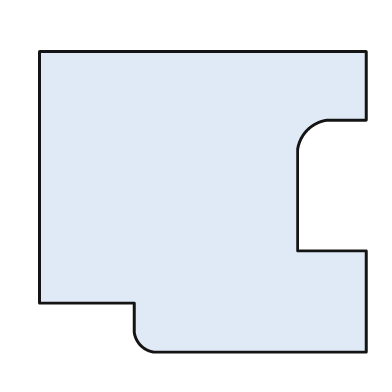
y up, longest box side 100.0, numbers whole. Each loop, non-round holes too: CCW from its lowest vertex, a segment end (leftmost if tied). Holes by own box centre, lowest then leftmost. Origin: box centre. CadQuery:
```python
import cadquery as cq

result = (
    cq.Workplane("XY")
    .moveTo(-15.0, -46.0)
    .lineTo(50.0, -46.0)
    .lineTo(50.0, -15.0)
    .lineTo(29.0, -15.0)
    .lineTo(29.0, 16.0)
    .threePointArc((32.0, 22.0), (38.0, 25.0))
    .lineTo(50.0, 25.0)
    .lineTo(50.0, 46.0)
    .lineTo(-50.0, 46.0)
    .lineTo(-50.0, -31.0)
    .lineTo(-21.0, -31.0)
    .lineTo(-21.0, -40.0)
    .threePointArc((-19.0, -44.0), (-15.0, -46.0))
    .close()
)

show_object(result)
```